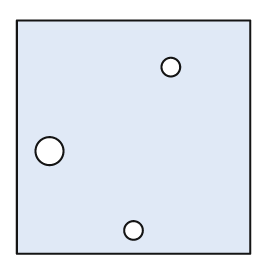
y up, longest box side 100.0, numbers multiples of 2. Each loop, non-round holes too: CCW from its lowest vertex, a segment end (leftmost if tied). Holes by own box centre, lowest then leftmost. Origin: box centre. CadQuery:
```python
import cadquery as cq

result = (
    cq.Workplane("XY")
    .moveTo(-50.0, -50.0)
    .lineTo(50.0, -50.0)
    .lineTo(50.0, 50.0)
    .lineTo(-50.0, 50.0)
    .close()
    .moveTo(0.0, -40.0)
    .circle(4.0)
    .moveTo(-36.0, -6.0)
    .circle(6.0)
    .moveTo(16.0, 30.0)
    .circle(4.0)
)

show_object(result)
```